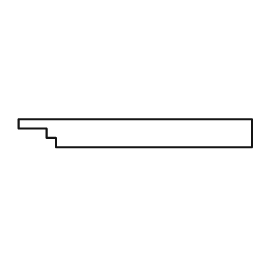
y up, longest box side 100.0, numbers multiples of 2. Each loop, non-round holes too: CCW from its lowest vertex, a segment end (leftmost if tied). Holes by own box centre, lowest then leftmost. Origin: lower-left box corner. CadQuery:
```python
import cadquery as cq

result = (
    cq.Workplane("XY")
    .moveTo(16.0, 0.0)
    .lineTo(100.0, 0.0)
    .lineTo(100.0, 12.0)
    .lineTo(0.0, 12.0)
    .lineTo(0.0, 8.0)
    .lineTo(12.0, 8.0)
    .lineTo(12.0, 4.0)
    .lineTo(16.0, 4.0)
    .close()
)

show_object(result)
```